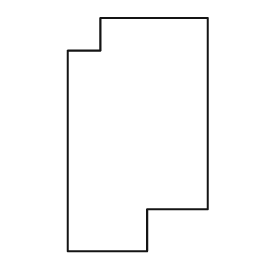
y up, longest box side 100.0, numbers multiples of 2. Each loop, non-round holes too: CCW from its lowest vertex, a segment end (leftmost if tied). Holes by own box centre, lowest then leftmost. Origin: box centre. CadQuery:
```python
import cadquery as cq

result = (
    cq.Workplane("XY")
    .moveTo(-30.0, -50.0)
    .lineTo(4.0, -50.0)
    .lineTo(4.0, -32.0)
    .lineTo(30.0, -32.0)
    .lineTo(30.0, 50.0)
    .lineTo(-16.0, 50.0)
    .lineTo(-16.0, 36.0)
    .lineTo(-30.0, 36.0)
    .close()
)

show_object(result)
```